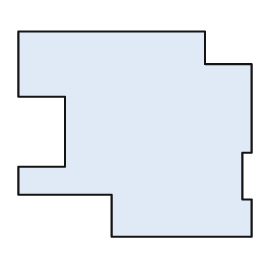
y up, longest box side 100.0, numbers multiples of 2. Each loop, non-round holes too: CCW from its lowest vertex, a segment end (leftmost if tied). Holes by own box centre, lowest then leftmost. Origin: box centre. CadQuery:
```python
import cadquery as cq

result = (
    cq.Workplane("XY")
    .moveTo(-10.0, -44.0)
    .lineTo(50.0, -44.0)
    .lineTo(50.0, -28.0)
    .lineTo(46.0, -28.0)
    .lineTo(46.0, -8.0)
    .lineTo(50.0, -8.0)
    .lineTo(50.0, 30.0)
    .lineTo(30.0, 30.0)
    .lineTo(30.0, 44.0)
    .lineTo(-50.0, 44.0)
    .lineTo(-50.0, 16.0)
    .lineTo(-30.0, 16.0)
    .lineTo(-30.0, -14.0)
    .lineTo(-50.0, -14.0)
    .lineTo(-50.0, -26.0)
    .lineTo(-10.0, -26.0)
    .close()
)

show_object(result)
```